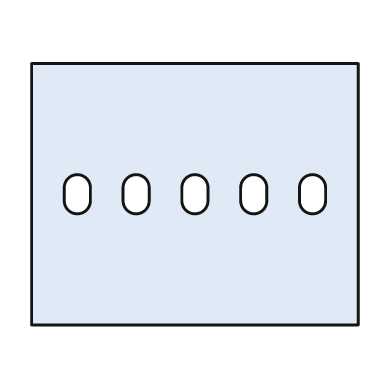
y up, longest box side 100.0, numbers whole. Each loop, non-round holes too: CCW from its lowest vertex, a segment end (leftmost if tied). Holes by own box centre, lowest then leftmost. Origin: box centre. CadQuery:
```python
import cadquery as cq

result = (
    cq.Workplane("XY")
    .moveTo(-50.0, -40.0)
    .lineTo(50.0, -40.0)
    .lineTo(50.0, 40.0)
    .lineTo(-50.0, 40.0)
    .close()
    .moveTo(-40.0, -2.0)
    .threePointArc((-36.0, -6.0), (-32.0, -2.0))
    .lineTo(-32.0, 2.0)
    .threePointArc((-36.0, 6.0), (-40.0, 2.0))
    .close()
    .moveTo(-22.0, -2.0)
    .threePointArc((-18.0, -6.0), (-14.0, -2.0))
    .lineTo(-14.0, 2.0)
    .threePointArc((-18.0, 6.0), (-22.0, 2.0))
    .close()
    .moveTo(-4.0, -2.0)
    .threePointArc((0.0, -6.0), (4.0, -2.0))
    .lineTo(4.0, 2.0)
    .threePointArc((0.0, 6.0), (-4.0, 2.0))
    .close()
    .moveTo(14.0, -2.0)
    .threePointArc((18.0, -6.0), (22.0, -2.0))
    .lineTo(22.0, 2.0)
    .threePointArc((18.0, 6.0), (14.0, 2.0))
    .close()
    .moveTo(32.0, -2.0)
    .threePointArc((36.0, -6.0), (40.0, -2.0))
    .lineTo(40.0, 2.0)
    .threePointArc((36.0, 6.0), (32.0, 2.0))
    .close()
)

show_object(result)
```